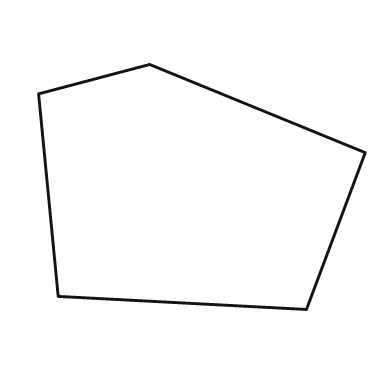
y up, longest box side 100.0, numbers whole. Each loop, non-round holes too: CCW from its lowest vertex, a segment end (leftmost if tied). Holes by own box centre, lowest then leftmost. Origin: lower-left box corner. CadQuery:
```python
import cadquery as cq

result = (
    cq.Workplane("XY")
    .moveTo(82.0, 0.0)
    .lineTo(100.0, 48.0)
    .lineTo(34.0, 75.0)
    .lineTo(0.0, 66.0)
    .lineTo(6.0, 4.0)
    .close()
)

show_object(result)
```